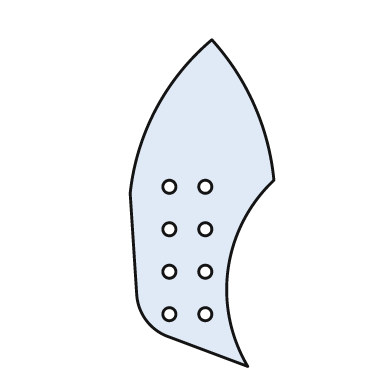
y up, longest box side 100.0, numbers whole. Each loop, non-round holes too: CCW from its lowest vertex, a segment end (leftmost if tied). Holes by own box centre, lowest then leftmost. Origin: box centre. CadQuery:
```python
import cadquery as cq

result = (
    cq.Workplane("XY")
    .moveTo(14.0, -50.0)
    .threePointArc((8.0, -20.0), (22.0, 7.0))
    .threePointArc((16.0, 30.0), (3.0, 50.0))
    .threePointArc((-14.0, 29.0), (-22.0, 3.0))
    .lineTo(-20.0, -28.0)
    .threePointArc((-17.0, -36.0), (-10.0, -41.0))
    .close()
    .moveTo(-10.0, -34.0)
    .circle(2.0)
    .moveTo(1.0, -34.0)
    .circle(2.0)
    .moveTo(-10.0, -21.0)
    .circle(2.0)
    .moveTo(1.0, -21.0)
    .circle(2.0)
    .moveTo(-10.0, -8.0)
    .circle(2.0)
    .moveTo(1.0, -8.0)
    .circle(2.0)
    .moveTo(-10.0, 5.0)
    .circle(2.0)
    .moveTo(1.0, 5.0)
    .circle(2.0)
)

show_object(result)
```